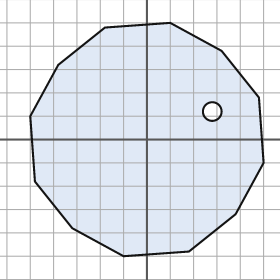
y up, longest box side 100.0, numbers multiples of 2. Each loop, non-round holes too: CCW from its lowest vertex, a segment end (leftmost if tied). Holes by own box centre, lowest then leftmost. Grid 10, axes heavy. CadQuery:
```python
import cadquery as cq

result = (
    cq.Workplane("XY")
    .moveTo(-10.0, -50.0)
    .lineTo(18.0, -48.0)
    .lineTo(38.0, -32.0)
    .lineTo(50.0, -10.0)
    .lineTo(48.0, 18.0)
    .lineTo(32.0, 38.0)
    .lineTo(10.0, 50.0)
    .lineTo(-18.0, 48.0)
    .lineTo(-38.0, 32.0)
    .lineTo(-50.0, 10.0)
    .lineTo(-48.0, -18.0)
    .lineTo(-32.0, -38.0)
    .close()
    .moveTo(28.0, 12.0)
    .circle(4.0)
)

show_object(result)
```